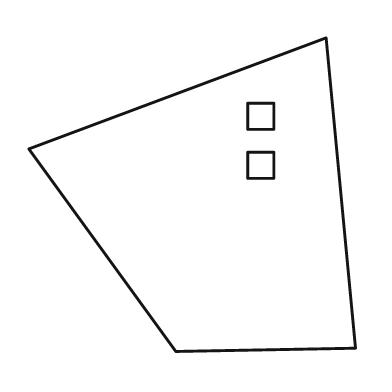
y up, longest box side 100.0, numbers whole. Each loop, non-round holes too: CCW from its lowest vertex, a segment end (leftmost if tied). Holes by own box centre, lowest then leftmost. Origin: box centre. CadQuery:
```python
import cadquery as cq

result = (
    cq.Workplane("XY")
    .moveTo(-5.0, -48.0)
    .lineTo(50.0, -47.0)
    .lineTo(41.0, 48.0)
    .lineTo(-50.0, 14.0)
    .close()
    .moveTo(17.0, 5.0)
    .lineTo(25.0, 5.0)
    .lineTo(25.0, 13.0)
    .lineTo(17.0, 13.0)
    .close()
    .moveTo(17.0, 20.0)
    .lineTo(25.0, 20.0)
    .lineTo(25.0, 28.0)
    .lineTo(17.0, 28.0)
    .close()
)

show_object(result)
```